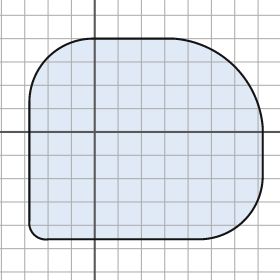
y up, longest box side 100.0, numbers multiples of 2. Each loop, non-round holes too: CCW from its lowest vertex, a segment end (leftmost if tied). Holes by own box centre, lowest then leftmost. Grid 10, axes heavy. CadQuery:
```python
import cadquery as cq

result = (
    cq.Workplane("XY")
    .moveTo(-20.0, -46.0)
    .lineTo(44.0, -46.0)
    .threePointArc((64.0, -38.0), (72.0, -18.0))
    .lineTo(72.0, 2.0)
    .threePointArc((60.0, 28.0), (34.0, 40.0))
    .lineTo(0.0, 40.0)
    .threePointArc((-20.0, 32.0), (-28.0, 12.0))
    .lineTo(-28.0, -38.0)
    .threePointArc((-26.0, -44.0), (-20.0, -46.0))
    .close()
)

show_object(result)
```